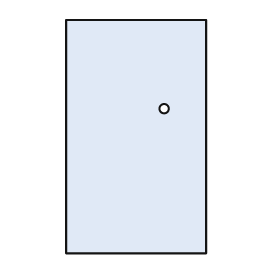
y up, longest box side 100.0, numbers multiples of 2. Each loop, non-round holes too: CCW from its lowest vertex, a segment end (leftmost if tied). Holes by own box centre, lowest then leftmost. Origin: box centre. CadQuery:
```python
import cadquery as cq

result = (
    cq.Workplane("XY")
    .moveTo(-30.0, -50.0)
    .lineTo(30.0, -50.0)
    .lineTo(30.0, 50.0)
    .lineTo(-30.0, 50.0)
    .close()
    .moveTo(12.0, 12.0)
    .circle(2.0)
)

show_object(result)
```